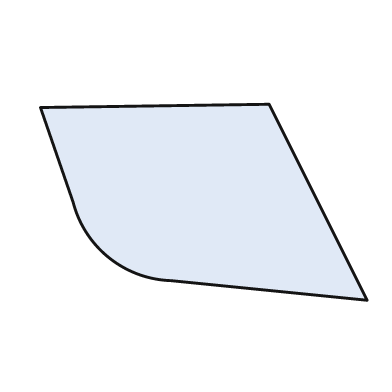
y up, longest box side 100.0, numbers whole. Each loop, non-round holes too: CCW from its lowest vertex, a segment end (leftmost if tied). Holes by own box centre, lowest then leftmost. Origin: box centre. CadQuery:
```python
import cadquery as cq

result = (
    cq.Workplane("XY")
    .moveTo(50.0, -30.0)
    .lineTo(20.0, 30.0)
    .lineTo(-50.0, 29.0)
    .lineTo(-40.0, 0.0)
    .threePointArc((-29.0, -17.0), (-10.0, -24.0))
    .close()
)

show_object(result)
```